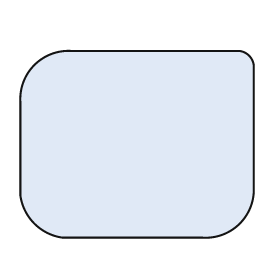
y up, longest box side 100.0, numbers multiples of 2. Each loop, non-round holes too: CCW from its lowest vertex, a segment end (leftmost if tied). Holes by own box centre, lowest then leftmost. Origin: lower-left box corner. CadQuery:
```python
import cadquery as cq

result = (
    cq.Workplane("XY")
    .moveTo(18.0, 0.0)
    .lineTo(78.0, 0.0)
    .threePointArc((94.0, 6.0), (100.0, 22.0))
    .lineTo(100.0, 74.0)
    .threePointArc((98.0, 78.0), (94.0, 80.0))
    .lineTo(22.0, 80.0)
    .threePointArc((6.0, 74.0), (0.0, 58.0))
    .lineTo(0.0, 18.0)
    .threePointArc((6.0, 6.0), (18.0, 0.0))
    .close()
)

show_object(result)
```